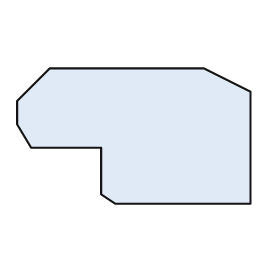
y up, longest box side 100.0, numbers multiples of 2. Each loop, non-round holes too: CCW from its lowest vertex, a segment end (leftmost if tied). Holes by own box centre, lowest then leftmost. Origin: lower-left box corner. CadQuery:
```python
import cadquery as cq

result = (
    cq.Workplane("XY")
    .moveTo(42.0, 0.0)
    .lineTo(100.0, 0.0)
    .lineTo(100.0, 48.0)
    .lineTo(80.0, 58.0)
    .lineTo(14.0, 58.0)
    .lineTo(0.0, 44.0)
    .lineTo(0.0, 34.0)
    .lineTo(6.0, 24.0)
    .lineTo(36.0, 24.0)
    .lineTo(36.0, 4.0)
    .close()
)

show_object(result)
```